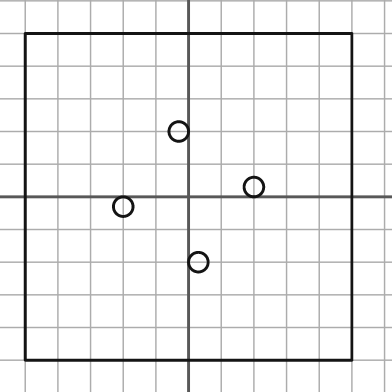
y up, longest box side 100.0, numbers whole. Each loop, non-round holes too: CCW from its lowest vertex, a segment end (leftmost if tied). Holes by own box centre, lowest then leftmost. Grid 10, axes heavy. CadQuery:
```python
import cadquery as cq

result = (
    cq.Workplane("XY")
    .moveTo(-50.0, -50.0)
    .lineTo(50.0, -50.0)
    .lineTo(50.0, 50.0)
    .lineTo(-50.0, 50.0)
    .close()
    .moveTo(3.0, -20.0)
    .circle(3.0)
    .moveTo(-20.0, -3.0)
    .circle(3.0)
    .moveTo(20.0, 3.0)
    .circle(3.0)
    .moveTo(-3.0, 20.0)
    .circle(3.0)
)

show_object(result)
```